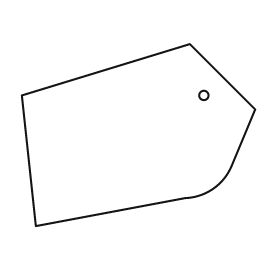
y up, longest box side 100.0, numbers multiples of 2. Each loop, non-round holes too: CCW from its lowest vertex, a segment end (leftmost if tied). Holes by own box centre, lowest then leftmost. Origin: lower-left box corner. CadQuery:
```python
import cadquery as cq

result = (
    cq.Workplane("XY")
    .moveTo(6.0, 0.0)
    .lineTo(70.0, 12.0)
    .threePointArc((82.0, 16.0), (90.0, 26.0))
    .lineTo(100.0, 50.0)
    .lineTo(72.0, 78.0)
    .lineTo(0.0, 56.0)
    .close()
    .moveTo(78.0, 56.0)
    .circle(2.0)
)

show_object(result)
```